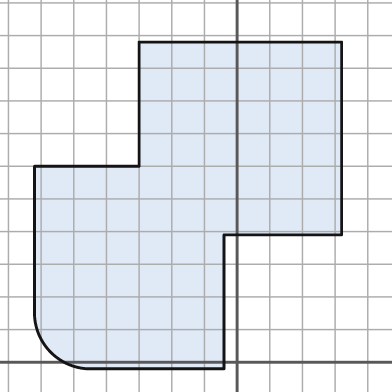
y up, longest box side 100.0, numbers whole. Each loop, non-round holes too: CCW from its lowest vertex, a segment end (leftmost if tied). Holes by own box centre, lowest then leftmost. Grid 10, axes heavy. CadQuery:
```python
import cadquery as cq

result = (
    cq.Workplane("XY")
    .moveTo(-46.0, -2.0)
    .lineTo(-4.0, -2.0)
    .lineTo(-4.0, 39.0)
    .lineTo(32.0, 39.0)
    .lineTo(32.0, 98.0)
    .lineTo(-30.0, 98.0)
    .lineTo(-30.0, 60.0)
    .lineTo(-62.0, 60.0)
    .lineTo(-62.0, 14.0)
    .threePointArc((-57.0, 3.0), (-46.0, -2.0))
    .close()
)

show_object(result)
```